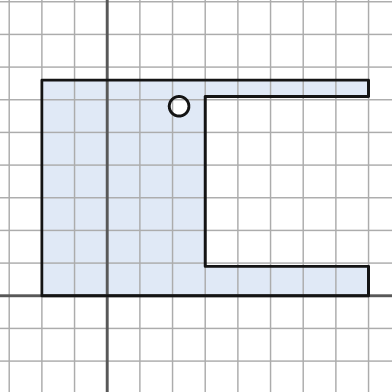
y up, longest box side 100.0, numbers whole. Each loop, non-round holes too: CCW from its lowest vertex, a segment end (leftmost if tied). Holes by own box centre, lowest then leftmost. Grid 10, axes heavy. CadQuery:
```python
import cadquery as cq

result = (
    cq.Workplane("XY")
    .moveTo(-20.0, 0.0)
    .lineTo(80.0, 0.0)
    .lineTo(80.0, 9.0)
    .lineTo(30.0, 9.0)
    .lineTo(30.0, 61.0)
    .lineTo(80.0, 61.0)
    .lineTo(80.0, 66.0)
    .lineTo(-20.0, 66.0)
    .close()
    .moveTo(22.0, 58.0)
    .circle(3.0)
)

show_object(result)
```